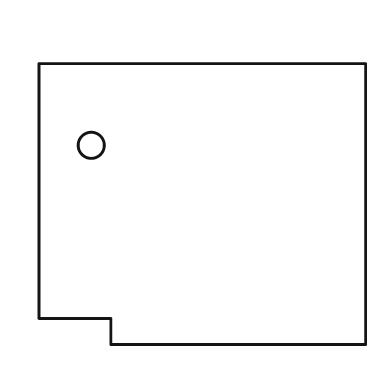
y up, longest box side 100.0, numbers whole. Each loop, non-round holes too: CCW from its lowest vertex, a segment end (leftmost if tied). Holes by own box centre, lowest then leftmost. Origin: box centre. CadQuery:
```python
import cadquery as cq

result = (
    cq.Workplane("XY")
    .moveTo(-28.0, -43.0)
    .lineTo(50.0, -43.0)
    .lineTo(50.0, 43.0)
    .lineTo(-50.0, 43.0)
    .lineTo(-50.0, -35.0)
    .lineTo(-28.0, -35.0)
    .close()
    .moveTo(-34.0, 18.0)
    .circle(4.0)
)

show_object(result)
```